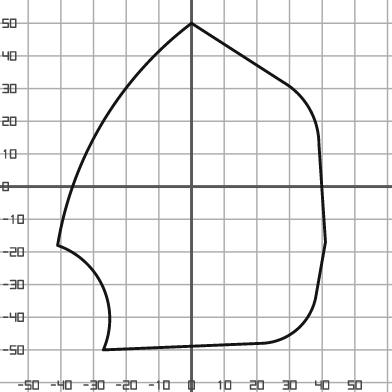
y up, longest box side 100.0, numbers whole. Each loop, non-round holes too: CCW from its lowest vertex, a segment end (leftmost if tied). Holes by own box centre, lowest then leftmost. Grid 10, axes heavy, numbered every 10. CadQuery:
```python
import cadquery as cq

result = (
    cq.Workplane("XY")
    .moveTo(-27.0, -50.0)
    .lineTo(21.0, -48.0)
    .threePointArc((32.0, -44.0), (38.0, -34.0))
    .lineTo(41.0, -17.0)
    .lineTo(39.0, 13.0)
    .threePointArc((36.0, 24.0), (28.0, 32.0))
    .lineTo(0.0, 50.0)
    .threePointArc((-27.0, 20.0), (-41.0, -18.0))
    .threePointArc((-27.0, -31.0), (-27.0, -50.0))
    .close()
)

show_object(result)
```